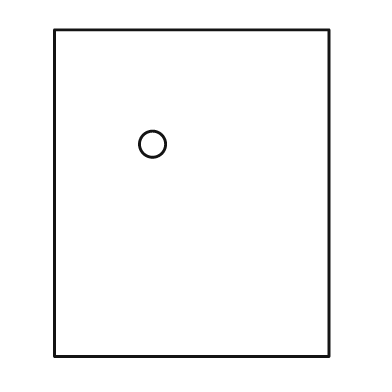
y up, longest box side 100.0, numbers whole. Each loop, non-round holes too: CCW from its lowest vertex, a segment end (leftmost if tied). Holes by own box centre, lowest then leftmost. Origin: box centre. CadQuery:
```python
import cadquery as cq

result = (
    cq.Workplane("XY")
    .moveTo(-42.0, -50.0)
    .lineTo(42.0, -50.0)
    .lineTo(42.0, 50.0)
    .lineTo(-42.0, 50.0)
    .close()
    .moveTo(-12.0, 15.0)
    .circle(4.0)
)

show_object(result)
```